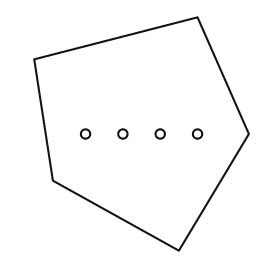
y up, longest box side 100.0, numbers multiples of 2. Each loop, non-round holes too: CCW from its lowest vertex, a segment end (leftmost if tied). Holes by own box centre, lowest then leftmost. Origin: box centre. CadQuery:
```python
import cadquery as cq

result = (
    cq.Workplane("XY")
    .moveTo(16.0, -50.0)
    .lineTo(46.0, 0.0)
    .lineTo(24.0, 50.0)
    .lineTo(-46.0, 32.0)
    .lineTo(-38.0, -20.0)
    .close()
    .moveTo(-24.0, 0.0)
    .circle(2.0)
    .moveTo(-8.0, 0.0)
    .circle(2.0)
    .moveTo(8.0, 0.0)
    .circle(2.0)
    .moveTo(24.0, 0.0)
    .circle(2.0)
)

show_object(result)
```